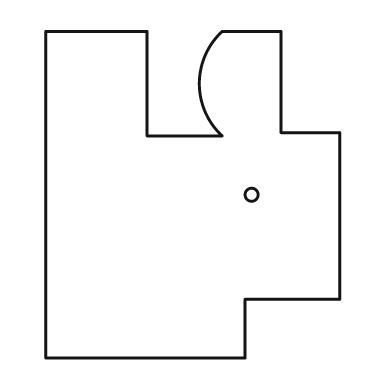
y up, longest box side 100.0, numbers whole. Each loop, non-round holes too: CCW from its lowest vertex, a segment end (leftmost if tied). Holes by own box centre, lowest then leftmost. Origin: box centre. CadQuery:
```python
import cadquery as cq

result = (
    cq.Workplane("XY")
    .moveTo(-45.0, -50.0)
    .lineTo(16.0, -50.0)
    .lineTo(16.0, -32.0)
    .lineTo(45.0, -32.0)
    .lineTo(45.0, 19.0)
    .lineTo(27.0, 19.0)
    .lineTo(27.0, 50.0)
    .lineTo(9.0, 50.0)
    .threePointArc((2.0, 34.0), (9.0, 18.0))
    .lineTo(-14.0, 18.0)
    .lineTo(-14.0, 50.0)
    .lineTo(-45.0, 50.0)
    .close()
    .moveTo(18.0, 0.0)
    .circle(2.0)
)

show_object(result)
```